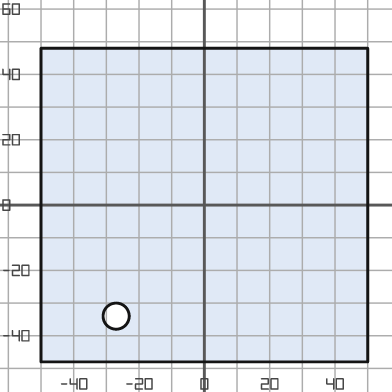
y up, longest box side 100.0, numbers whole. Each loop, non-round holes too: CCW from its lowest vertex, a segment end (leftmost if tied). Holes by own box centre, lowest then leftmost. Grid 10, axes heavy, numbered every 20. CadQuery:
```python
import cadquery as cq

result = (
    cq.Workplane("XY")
    .moveTo(-50.0, -48.0)
    .lineTo(50.0, -48.0)
    .lineTo(50.0, 48.0)
    .lineTo(-50.0, 48.0)
    .close()
    .moveTo(-27.0, -34.0)
    .circle(4.0)
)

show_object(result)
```